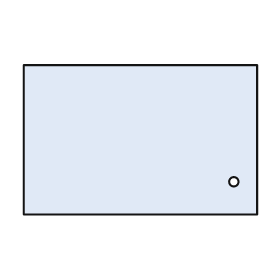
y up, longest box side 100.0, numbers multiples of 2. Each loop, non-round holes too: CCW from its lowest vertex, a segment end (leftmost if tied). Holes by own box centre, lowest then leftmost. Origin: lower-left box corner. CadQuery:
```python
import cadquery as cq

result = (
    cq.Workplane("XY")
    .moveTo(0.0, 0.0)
    .lineTo(100.0, 0.0)
    .lineTo(100.0, 64.0)
    .lineTo(0.0, 64.0)
    .close()
    .moveTo(90.0, 14.0)
    .circle(2.0)
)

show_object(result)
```